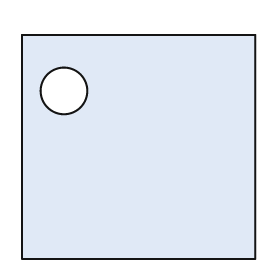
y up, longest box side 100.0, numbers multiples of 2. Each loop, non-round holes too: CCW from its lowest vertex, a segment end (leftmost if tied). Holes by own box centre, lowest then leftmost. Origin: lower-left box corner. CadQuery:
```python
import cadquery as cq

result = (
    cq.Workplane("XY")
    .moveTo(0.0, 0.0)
    .lineTo(100.0, 0.0)
    .lineTo(100.0, 96.0)
    .lineTo(0.0, 96.0)
    .close()
    .moveTo(18.0, 72.0)
    .circle(10.0)
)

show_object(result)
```